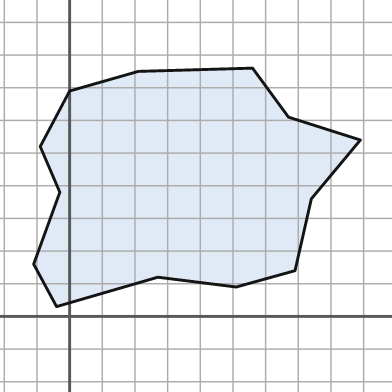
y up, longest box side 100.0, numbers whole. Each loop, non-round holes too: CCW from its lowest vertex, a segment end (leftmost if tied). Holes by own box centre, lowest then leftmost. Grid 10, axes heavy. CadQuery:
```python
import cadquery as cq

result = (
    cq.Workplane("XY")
    .moveTo(-4.0, 3.0)
    .lineTo(27.0, 12.0)
    .lineTo(51.0, 9.0)
    .lineTo(69.0, 14.0)
    .lineTo(74.0, 36.0)
    .lineTo(89.0, 54.0)
    .lineTo(67.0, 61.0)
    .lineTo(56.0, 76.0)
    .lineTo(21.0, 75.0)
    .lineTo(0.0, 69.0)
    .lineTo(-9.0, 52.0)
    .lineTo(-3.0, 38.0)
    .lineTo(-11.0, 16.0)
    .close()
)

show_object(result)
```